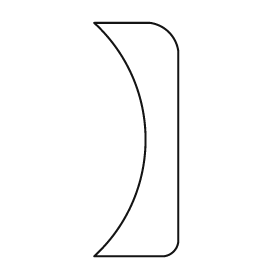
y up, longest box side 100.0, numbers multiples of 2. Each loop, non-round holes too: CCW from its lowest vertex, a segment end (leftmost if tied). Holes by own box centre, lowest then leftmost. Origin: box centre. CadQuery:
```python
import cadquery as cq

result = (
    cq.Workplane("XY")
    .moveTo(-18.0, -50.0)
    .lineTo(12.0, -50.0)
    .threePointArc((16.0, -48.0), (18.0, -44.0))
    .lineTo(18.0, 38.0)
    .threePointArc((14.0, 46.0), (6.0, 50.0))
    .lineTo(-18.0, 50.0)
    .threePointArc((4.0, 0.0), (-18.0, -50.0))
    .close()
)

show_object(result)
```